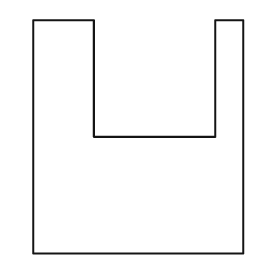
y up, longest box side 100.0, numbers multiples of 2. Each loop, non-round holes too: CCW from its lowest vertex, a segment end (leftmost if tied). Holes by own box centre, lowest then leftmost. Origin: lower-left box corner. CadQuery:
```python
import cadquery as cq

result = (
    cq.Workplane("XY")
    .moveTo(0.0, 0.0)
    .lineTo(90.0, 0.0)
    .lineTo(90.0, 100.0)
    .lineTo(78.0, 100.0)
    .lineTo(78.0, 50.0)
    .lineTo(26.0, 50.0)
    .lineTo(26.0, 100.0)
    .lineTo(0.0, 100.0)
    .close()
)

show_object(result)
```